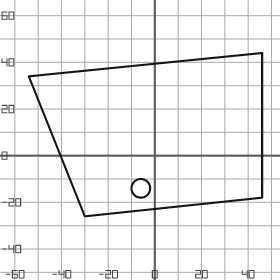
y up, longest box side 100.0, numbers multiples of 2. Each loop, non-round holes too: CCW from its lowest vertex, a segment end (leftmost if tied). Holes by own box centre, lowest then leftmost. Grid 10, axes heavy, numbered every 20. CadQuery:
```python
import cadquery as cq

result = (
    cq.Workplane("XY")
    .moveTo(-30.0, -26.0)
    .lineTo(46.0, -18.0)
    .lineTo(46.0, 44.0)
    .lineTo(-54.0, 34.0)
    .close()
    .moveTo(-6.0, -14.0)
    .circle(4.0)
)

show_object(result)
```